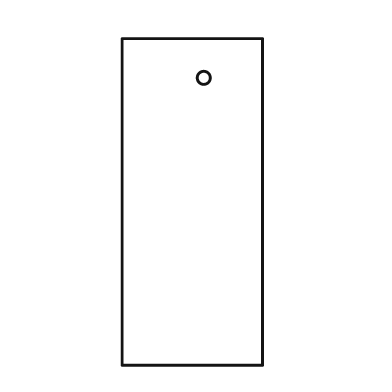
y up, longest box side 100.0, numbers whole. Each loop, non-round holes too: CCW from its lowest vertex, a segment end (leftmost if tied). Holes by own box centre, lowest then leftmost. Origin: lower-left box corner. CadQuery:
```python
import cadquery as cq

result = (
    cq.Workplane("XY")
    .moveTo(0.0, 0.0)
    .lineTo(43.0, 0.0)
    .lineTo(43.0, 100.0)
    .lineTo(0.0, 100.0)
    .close()
    .moveTo(25.0, 88.0)
    .circle(2.0)
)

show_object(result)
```